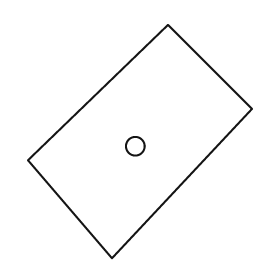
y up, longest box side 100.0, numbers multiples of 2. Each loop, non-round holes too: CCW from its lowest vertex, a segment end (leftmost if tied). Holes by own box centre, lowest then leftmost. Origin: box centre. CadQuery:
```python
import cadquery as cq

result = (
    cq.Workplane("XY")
    .moveTo(-12.0, -50.0)
    .lineTo(48.0, 14.0)
    .lineTo(12.0, 50.0)
    .lineTo(-48.0, -8.0)
    .close()
    .moveTo(-2.0, -2.0)
    .circle(4.0)
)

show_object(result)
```